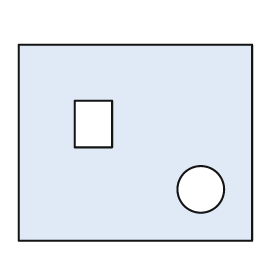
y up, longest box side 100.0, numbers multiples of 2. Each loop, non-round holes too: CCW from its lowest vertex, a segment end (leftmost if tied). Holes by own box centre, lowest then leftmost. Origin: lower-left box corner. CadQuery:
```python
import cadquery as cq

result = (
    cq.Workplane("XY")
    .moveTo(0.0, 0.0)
    .lineTo(100.0, 0.0)
    .lineTo(100.0, 84.0)
    .lineTo(0.0, 84.0)
    .close()
    .moveTo(78.0, 22.0)
    .circle(10.0)
    .moveTo(24.0, 40.0)
    .lineTo(40.0, 40.0)
    .lineTo(40.0, 60.0)
    .lineTo(24.0, 60.0)
    .close()
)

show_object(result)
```